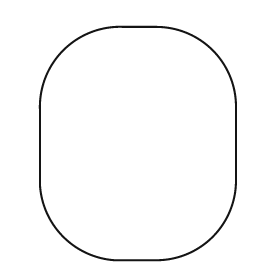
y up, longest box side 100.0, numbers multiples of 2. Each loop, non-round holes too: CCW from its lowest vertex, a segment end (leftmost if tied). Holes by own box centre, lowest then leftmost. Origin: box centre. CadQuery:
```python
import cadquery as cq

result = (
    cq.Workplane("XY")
    .moveTo(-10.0, -50.0)
    .lineTo(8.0, -50.0)
    .threePointArc((32.0, -40.0), (42.0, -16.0))
    .lineTo(42.0, 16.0)
    .threePointArc((32.0, 40.0), (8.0, 50.0))
    .lineTo(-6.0, 50.0)
    .threePointArc((-32.0, 40.0), (-42.0, 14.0))
    .lineTo(-42.0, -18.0)
    .threePointArc((-32.0, -40.0), (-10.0, -50.0))
    .close()
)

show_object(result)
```